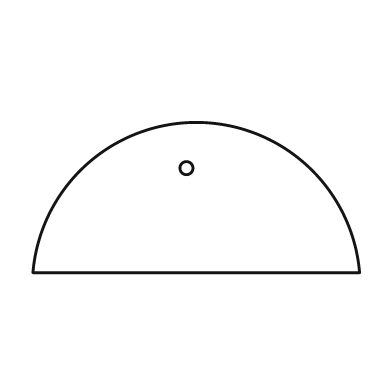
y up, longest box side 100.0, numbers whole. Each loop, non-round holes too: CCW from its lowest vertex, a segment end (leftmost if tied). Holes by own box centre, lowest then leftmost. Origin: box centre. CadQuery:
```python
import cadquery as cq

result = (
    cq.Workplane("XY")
    .moveTo(-50.0, -23.0)
    .lineTo(50.0, -23.0)
    .threePointArc((0.0, 23.0), (-50.0, -23.0))
    .close()
    .moveTo(-3.0, 9.0)
    .circle(2.0)
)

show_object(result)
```